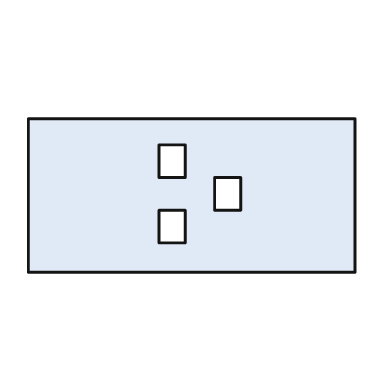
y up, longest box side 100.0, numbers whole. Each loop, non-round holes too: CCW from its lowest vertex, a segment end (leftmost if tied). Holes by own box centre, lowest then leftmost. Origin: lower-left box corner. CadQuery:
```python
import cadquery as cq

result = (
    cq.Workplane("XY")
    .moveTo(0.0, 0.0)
    .lineTo(100.0, 0.0)
    .lineTo(100.0, 47.0)
    .lineTo(0.0, 47.0)
    .close()
    .moveTo(40.0, 9.0)
    .lineTo(48.0, 9.0)
    .lineTo(48.0, 19.0)
    .lineTo(40.0, 19.0)
    .close()
    .moveTo(57.0, 19.0)
    .lineTo(65.0, 19.0)
    .lineTo(65.0, 29.0)
    .lineTo(57.0, 29.0)
    .close()
    .moveTo(40.0, 29.0)
    .lineTo(48.0, 29.0)
    .lineTo(48.0, 39.0)
    .lineTo(40.0, 39.0)
    .close()
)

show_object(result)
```